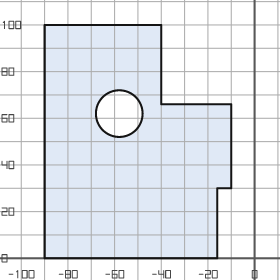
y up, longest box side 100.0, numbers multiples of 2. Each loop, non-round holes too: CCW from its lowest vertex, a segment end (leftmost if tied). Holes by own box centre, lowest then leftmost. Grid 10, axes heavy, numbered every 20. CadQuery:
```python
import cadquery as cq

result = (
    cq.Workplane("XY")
    .moveTo(-90.0, 0.0)
    .lineTo(-16.0, 0.0)
    .lineTo(-16.0, 30.0)
    .lineTo(-10.0, 30.0)
    .lineTo(-10.0, 66.0)
    .lineTo(-40.0, 66.0)
    .lineTo(-40.0, 100.0)
    .lineTo(-90.0, 100.0)
    .close()
    .moveTo(-58.0, 62.0)
    .circle(10.0)
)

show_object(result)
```